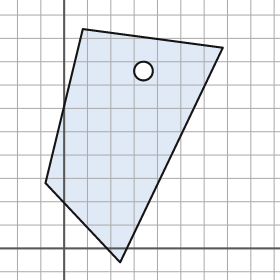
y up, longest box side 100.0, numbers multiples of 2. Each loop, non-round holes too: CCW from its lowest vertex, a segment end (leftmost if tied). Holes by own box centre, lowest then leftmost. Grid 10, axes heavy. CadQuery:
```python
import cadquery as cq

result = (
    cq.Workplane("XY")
    .moveTo(24.0, -6.0)
    .lineTo(68.0, 86.0)
    .lineTo(8.0, 94.0)
    .lineTo(-8.0, 28.0)
    .close()
    .moveTo(34.0, 76.0)
    .circle(4.0)
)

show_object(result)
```